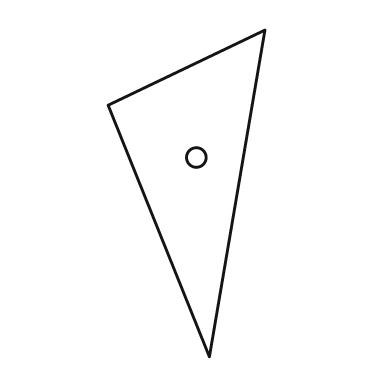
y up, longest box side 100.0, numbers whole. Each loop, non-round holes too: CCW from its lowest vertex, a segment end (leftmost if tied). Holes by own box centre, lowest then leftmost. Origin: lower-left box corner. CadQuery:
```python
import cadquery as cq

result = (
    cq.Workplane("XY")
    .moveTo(31.0, 0.0)
    .lineTo(48.0, 100.0)
    .lineTo(0.0, 77.0)
    .close()
    .moveTo(27.0, 61.0)
    .circle(3.0)
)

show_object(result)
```